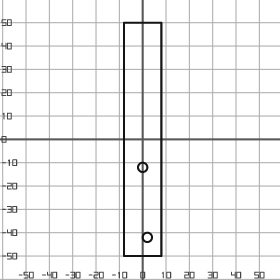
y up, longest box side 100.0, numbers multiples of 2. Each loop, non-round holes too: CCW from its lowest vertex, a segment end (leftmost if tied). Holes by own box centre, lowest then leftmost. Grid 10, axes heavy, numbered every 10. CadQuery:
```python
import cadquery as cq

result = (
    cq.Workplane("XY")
    .moveTo(-8.0, -50.0)
    .lineTo(8.0, -50.0)
    .lineTo(8.0, 50.0)
    .lineTo(-8.0, 50.0)
    .close()
    .moveTo(2.0, -42.0)
    .circle(2.0)
    .moveTo(0.0, -12.0)
    .circle(2.0)
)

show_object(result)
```